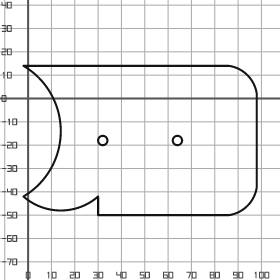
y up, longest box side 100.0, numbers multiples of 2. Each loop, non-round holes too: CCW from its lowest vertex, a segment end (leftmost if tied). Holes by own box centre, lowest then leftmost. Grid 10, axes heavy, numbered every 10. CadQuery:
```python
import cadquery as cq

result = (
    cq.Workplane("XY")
    .moveTo(30.0, -50.0)
    .lineTo(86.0, -50.0)
    .threePointArc((94.0, -46.0), (98.0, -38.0))
    .lineTo(98.0, 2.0)
    .threePointArc((94.0, 10.0), (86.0, 14.0))
    .lineTo(-2.0, 14.0)
    .threePointArc((14.0, -14.0), (-2.0, -42.0))
    .threePointArc((14.0, -48.0), (30.0, -42.0))
    .close()
    .moveTo(32.0, -18.0)
    .circle(2.0)
    .moveTo(64.0, -18.0)
    .circle(2.0)
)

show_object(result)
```